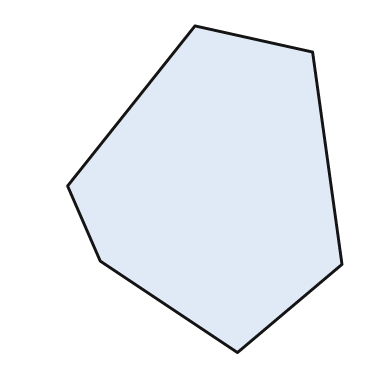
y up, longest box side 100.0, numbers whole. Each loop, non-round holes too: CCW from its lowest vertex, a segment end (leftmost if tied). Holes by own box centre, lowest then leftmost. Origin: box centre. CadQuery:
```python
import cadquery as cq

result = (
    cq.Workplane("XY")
    .moveTo(10.0, -50.0)
    .lineTo(42.0, -23.0)
    .lineTo(33.0, 42.0)
    .lineTo(-3.0, 50.0)
    .lineTo(-42.0, 1.0)
    .lineTo(-32.0, -22.0)
    .close()
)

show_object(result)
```